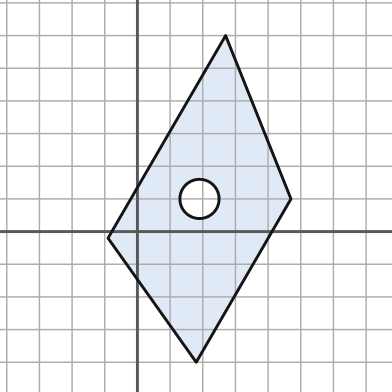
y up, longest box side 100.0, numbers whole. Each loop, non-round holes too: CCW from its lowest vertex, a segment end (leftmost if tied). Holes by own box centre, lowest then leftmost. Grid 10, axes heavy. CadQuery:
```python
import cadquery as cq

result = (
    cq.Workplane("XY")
    .moveTo(18.0, -40.0)
    .lineTo(47.0, 10.0)
    .lineTo(27.0, 60.0)
    .lineTo(-9.0, -2.0)
    .close()
    .moveTo(19.0, 10.0)
    .circle(6.0)
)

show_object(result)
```